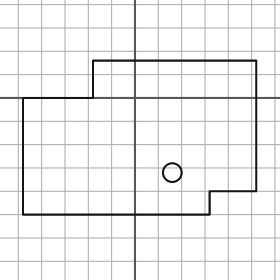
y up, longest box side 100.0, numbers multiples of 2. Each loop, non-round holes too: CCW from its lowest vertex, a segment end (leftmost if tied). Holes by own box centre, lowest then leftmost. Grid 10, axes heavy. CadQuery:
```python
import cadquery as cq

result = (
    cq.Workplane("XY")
    .moveTo(-48.0, -50.0)
    .lineTo(32.0, -50.0)
    .lineTo(32.0, -40.0)
    .lineTo(52.0, -40.0)
    .lineTo(52.0, 16.0)
    .lineTo(-18.0, 16.0)
    .lineTo(-18.0, 0.0)
    .lineTo(-48.0, 0.0)
    .close()
    .moveTo(16.0, -32.0)
    .circle(4.0)
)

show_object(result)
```